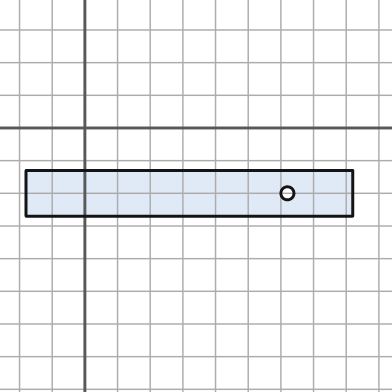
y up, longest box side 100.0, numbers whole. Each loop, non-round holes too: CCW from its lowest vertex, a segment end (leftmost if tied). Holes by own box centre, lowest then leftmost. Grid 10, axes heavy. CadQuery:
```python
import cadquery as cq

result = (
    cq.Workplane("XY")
    .moveTo(-18.0, -27.0)
    .lineTo(82.0, -27.0)
    .lineTo(82.0, -13.0)
    .lineTo(-18.0, -13.0)
    .close()
    .moveTo(62.0, -20.0)
    .circle(2.0)
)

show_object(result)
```